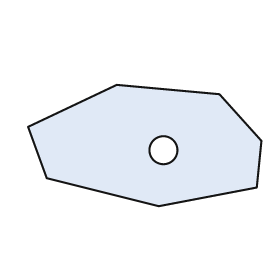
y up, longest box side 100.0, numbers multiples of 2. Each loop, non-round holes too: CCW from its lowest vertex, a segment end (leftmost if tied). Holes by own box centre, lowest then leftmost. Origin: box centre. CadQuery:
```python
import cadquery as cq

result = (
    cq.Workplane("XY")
    .moveTo(6.0, -26.0)
    .lineTo(48.0, -18.0)
    .lineTo(50.0, 2.0)
    .lineTo(32.0, 22.0)
    .lineTo(-12.0, 26.0)
    .lineTo(-50.0, 8.0)
    .lineTo(-42.0, -14.0)
    .close()
    .moveTo(8.0, -2.0)
    .circle(6.0)
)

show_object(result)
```